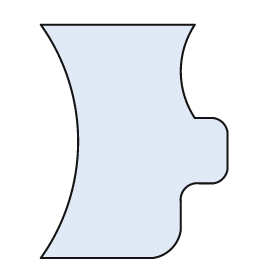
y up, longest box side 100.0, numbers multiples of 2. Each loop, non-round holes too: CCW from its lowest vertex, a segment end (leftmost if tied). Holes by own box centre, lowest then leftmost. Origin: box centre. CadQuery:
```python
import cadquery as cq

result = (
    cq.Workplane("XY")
    .moveTo(-40.0, -50.0)
    .lineTo(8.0, -50.0)
    .threePointArc((16.0, -46.0), (20.0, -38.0))
    .lineTo(20.0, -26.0)
    .threePointArc((22.0, -20.0), (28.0, -18.0))
    .lineTo(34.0, -18.0)
    .threePointArc((38.0, -16.0), (40.0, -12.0))
    .lineTo(40.0, 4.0)
    .threePointArc((38.0, 8.0), (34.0, 10.0))
    .lineTo(26.0, 10.0)
    .threePointArc((20.0, 30.0), (26.0, 50.0))
    .lineTo(-40.0, 50.0)
    .threePointArc((-24.0, 0.0), (-40.0, -50.0))
    .close()
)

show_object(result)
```